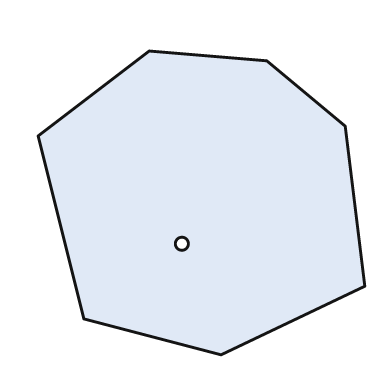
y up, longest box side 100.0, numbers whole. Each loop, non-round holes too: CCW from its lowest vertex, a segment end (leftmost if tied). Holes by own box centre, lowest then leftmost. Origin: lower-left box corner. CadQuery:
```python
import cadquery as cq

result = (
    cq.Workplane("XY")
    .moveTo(56.0, 0.0)
    .lineTo(100.0, 21.0)
    .lineTo(94.0, 70.0)
    .lineTo(70.0, 90.0)
    .lineTo(34.0, 93.0)
    .lineTo(0.0, 67.0)
    .lineTo(14.0, 11.0)
    .close()
    .moveTo(44.0, 34.0)
    .circle(2.0)
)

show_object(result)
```